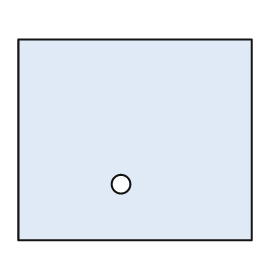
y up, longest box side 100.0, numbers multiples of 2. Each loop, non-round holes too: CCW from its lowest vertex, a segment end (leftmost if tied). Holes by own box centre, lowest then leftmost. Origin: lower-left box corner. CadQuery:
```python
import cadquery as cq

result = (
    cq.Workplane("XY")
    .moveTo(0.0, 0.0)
    .lineTo(100.0, 0.0)
    .lineTo(100.0, 86.0)
    .lineTo(0.0, 86.0)
    .close()
    .moveTo(44.0, 24.0)
    .circle(4.0)
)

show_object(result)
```